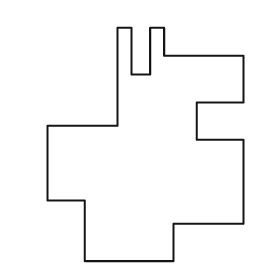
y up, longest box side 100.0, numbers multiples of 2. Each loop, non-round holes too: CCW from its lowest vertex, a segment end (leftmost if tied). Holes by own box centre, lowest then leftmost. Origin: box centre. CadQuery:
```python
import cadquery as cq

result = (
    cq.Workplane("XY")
    .moveTo(-26.0, -50.0)
    .lineTo(12.0, -50.0)
    .lineTo(12.0, -34.0)
    .lineTo(42.0, -34.0)
    .lineTo(42.0, 2.0)
    .lineTo(22.0, 2.0)
    .lineTo(22.0, 18.0)
    .lineTo(42.0, 18.0)
    .lineTo(42.0, 38.0)
    .lineTo(8.0, 38.0)
    .lineTo(8.0, 50.0)
    .lineTo(2.0, 50.0)
    .lineTo(2.0, 30.0)
    .lineTo(-6.0, 30.0)
    .lineTo(-6.0, 50.0)
    .lineTo(-12.0, 50.0)
    .lineTo(-12.0, 8.0)
    .lineTo(-42.0, 8.0)
    .lineTo(-42.0, -24.0)
    .lineTo(-26.0, -24.0)
    .close()
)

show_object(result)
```